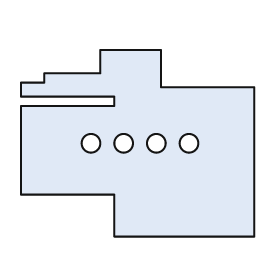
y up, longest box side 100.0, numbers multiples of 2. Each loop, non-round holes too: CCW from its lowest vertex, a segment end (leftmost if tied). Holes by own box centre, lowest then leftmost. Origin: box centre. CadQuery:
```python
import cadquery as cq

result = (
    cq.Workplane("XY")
    .moveTo(-10.0, -40.0)
    .lineTo(50.0, -40.0)
    .lineTo(50.0, 24.0)
    .lineTo(10.0, 24.0)
    .lineTo(10.0, 40.0)
    .lineTo(-16.0, 40.0)
    .lineTo(-16.0, 30.0)
    .lineTo(-40.0, 30.0)
    .lineTo(-40.0, 26.0)
    .lineTo(-50.0, 26.0)
    .lineTo(-50.0, 20.0)
    .lineTo(-10.0, 20.0)
    .lineTo(-10.0, 16.0)
    .lineTo(-50.0, 16.0)
    .lineTo(-50.0, -22.0)
    .lineTo(-10.0, -22.0)
    .close()
    .moveTo(-20.0, 0.0)
    .circle(4.0)
    .moveTo(-6.0, 0.0)
    .circle(4.0)
    .moveTo(8.0, 0.0)
    .circle(4.0)
    .moveTo(22.0, 0.0)
    .circle(4.0)
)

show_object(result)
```